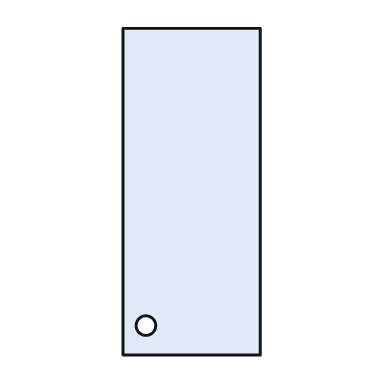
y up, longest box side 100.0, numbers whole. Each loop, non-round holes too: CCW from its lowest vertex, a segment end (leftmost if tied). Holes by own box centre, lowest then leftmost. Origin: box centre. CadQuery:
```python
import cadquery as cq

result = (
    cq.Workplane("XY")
    .moveTo(-21.0, -50.0)
    .lineTo(21.0, -50.0)
    .lineTo(21.0, 50.0)
    .lineTo(-21.0, 50.0)
    .close()
    .moveTo(-14.0, -41.0)
    .circle(3.0)
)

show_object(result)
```